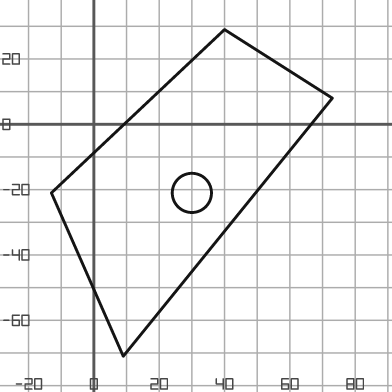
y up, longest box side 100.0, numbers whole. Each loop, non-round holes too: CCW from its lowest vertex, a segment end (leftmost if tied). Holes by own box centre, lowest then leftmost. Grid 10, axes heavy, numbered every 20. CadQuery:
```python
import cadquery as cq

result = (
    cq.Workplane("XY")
    .moveTo(9.0, -71.0)
    .lineTo(73.0, 8.0)
    .lineTo(40.0, 29.0)
    .lineTo(-13.0, -21.0)
    .close()
    .moveTo(30.0, -21.0)
    .circle(6.0)
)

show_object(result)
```